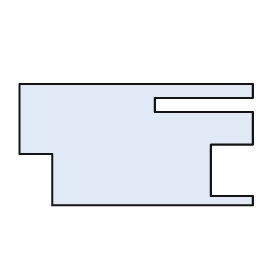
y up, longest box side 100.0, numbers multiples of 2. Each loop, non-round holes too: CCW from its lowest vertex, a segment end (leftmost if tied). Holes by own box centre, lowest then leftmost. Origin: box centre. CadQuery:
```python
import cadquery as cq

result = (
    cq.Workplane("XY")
    .moveTo(-36.0, -26.0)
    .lineTo(50.0, -26.0)
    .lineTo(50.0, -22.0)
    .lineTo(32.0, -22.0)
    .lineTo(32.0, 0.0)
    .lineTo(50.0, 0.0)
    .lineTo(50.0, 14.0)
    .lineTo(8.0, 14.0)
    .lineTo(8.0, 20.0)
    .lineTo(50.0, 20.0)
    .lineTo(50.0, 26.0)
    .lineTo(-50.0, 26.0)
    .lineTo(-50.0, -4.0)
    .lineTo(-36.0, -4.0)
    .close()
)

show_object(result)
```